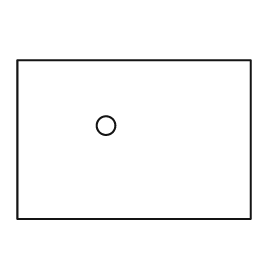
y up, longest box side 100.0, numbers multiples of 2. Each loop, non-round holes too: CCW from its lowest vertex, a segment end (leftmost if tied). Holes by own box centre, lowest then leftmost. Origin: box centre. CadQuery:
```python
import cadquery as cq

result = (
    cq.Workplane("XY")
    .moveTo(-50.0, -34.0)
    .lineTo(50.0, -34.0)
    .lineTo(50.0, 34.0)
    .lineTo(-50.0, 34.0)
    .close()
    .moveTo(-12.0, 6.0)
    .circle(4.0)
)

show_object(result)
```